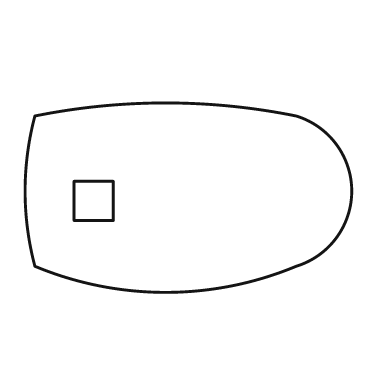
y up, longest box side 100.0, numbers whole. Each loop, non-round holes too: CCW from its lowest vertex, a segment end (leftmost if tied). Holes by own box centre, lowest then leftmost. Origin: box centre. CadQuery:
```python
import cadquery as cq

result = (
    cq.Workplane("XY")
    .moveTo(-47.0, -21.0)
    .threePointArc((-7.0, -29.0), (33.0, -21.0))
    .threePointArc((50.0, 2.0), (33.0, 25.0))
    .threePointArc((-7.0, 29.0), (-47.0, 25.0))
    .threePointArc((-50.0, 2.0), (-47.0, -21.0))
    .close()
    .moveTo(-35.0, -7.0)
    .lineTo(-23.0, -7.0)
    .lineTo(-23.0, 5.0)
    .lineTo(-35.0, 5.0)
    .close()
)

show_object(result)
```